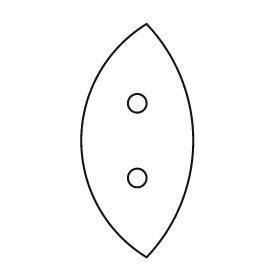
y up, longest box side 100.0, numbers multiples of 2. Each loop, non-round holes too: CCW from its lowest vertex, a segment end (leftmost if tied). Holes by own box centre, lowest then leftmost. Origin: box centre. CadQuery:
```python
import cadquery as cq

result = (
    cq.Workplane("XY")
    .moveTo(4.0, -50.0)
    .threePointArc((24.0, 0.0), (4.0, 50.0))
    .threePointArc((-24.0, 0.0), (4.0, -50.0))
    .close()
    .moveTo(0.0, -16.0)
    .circle(4.0)
    .moveTo(0.0, 16.0)
    .circle(4.0)
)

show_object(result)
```